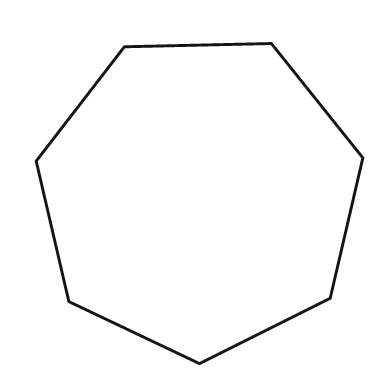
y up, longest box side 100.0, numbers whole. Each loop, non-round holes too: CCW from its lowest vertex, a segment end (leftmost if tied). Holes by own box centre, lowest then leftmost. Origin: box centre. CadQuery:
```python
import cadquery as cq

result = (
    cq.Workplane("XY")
    .moveTo(0.0, -49.0)
    .lineTo(40.0, -29.0)
    .lineTo(50.0, 14.0)
    .lineTo(22.0, 49.0)
    .lineTo(-23.0, 48.0)
    .lineTo(-50.0, 13.0)
    .lineTo(-40.0, -30.0)
    .close()
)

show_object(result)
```